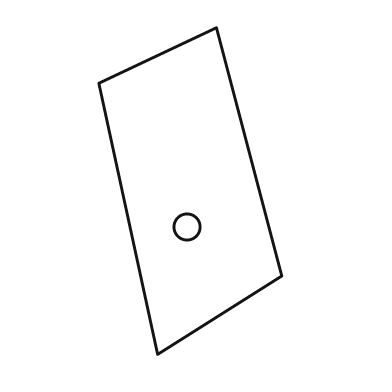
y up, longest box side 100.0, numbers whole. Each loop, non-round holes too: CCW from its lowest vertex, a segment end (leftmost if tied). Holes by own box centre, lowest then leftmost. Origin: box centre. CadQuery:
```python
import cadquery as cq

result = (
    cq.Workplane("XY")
    .moveTo(-10.0, -50.0)
    .lineTo(28.0, -26.0)
    .lineTo(8.0, 50.0)
    .lineTo(-28.0, 33.0)
    .close()
    .moveTo(-1.0, -11.0)
    .circle(4.0)
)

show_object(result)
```